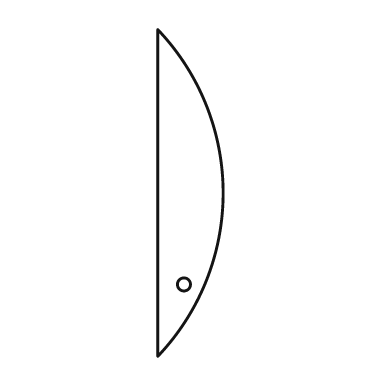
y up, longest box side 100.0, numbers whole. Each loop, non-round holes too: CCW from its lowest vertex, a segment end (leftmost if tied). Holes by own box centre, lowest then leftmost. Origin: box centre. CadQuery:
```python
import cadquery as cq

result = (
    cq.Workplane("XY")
    .moveTo(-10.0, -50.0)
    .threePointArc((10.0, 0.0), (-10.0, 50.0))
    .close()
    .moveTo(-2.0, -28.0)
    .circle(2.0)
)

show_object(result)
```